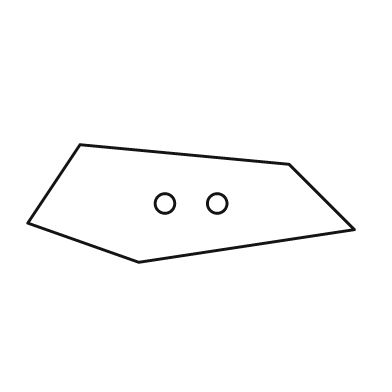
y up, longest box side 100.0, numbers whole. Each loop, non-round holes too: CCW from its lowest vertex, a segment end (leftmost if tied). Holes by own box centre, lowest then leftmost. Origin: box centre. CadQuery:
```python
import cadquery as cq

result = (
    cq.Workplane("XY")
    .moveTo(-16.0, -18.0)
    .lineTo(50.0, -8.0)
    .lineTo(30.0, 12.0)
    .lineTo(-34.0, 18.0)
    .lineTo(-50.0, -6.0)
    .close()
    .moveTo(-8.0, 0.0)
    .circle(3.0)
    .moveTo(8.0, 0.0)
    .circle(3.0)
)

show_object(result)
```